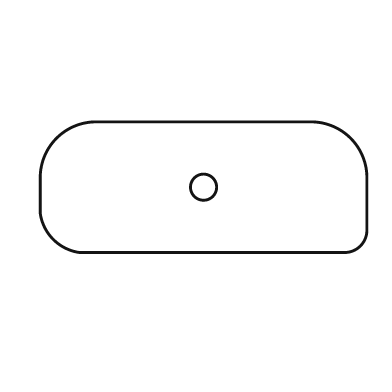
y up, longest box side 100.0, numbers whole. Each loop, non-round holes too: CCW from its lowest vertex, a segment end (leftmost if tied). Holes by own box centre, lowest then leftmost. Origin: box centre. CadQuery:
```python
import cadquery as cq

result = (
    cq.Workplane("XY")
    .moveTo(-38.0, -20.0)
    .lineTo(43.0, -20.0)
    .threePointArc((48.0, -18.0), (50.0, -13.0))
    .lineTo(50.0, 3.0)
    .threePointArc((45.0, 15.0), (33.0, 20.0))
    .lineTo(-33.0, 20.0)
    .threePointArc((-45.0, 15.0), (-50.0, 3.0))
    .lineTo(-50.0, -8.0)
    .threePointArc((-46.0, -16.0), (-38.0, -20.0))
    .close()
    .moveTo(0.0, 0.0)
    .circle(4.0)
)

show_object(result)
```